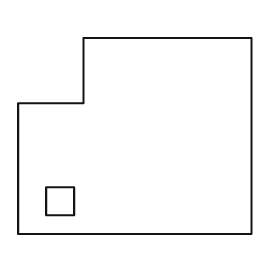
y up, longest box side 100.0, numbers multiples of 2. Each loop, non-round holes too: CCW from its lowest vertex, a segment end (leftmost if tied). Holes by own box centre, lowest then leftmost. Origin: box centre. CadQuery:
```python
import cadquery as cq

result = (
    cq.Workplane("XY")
    .moveTo(-50.0, -42.0)
    .lineTo(50.0, -42.0)
    .lineTo(50.0, 42.0)
    .lineTo(-22.0, 42.0)
    .lineTo(-22.0, 14.0)
    .lineTo(-50.0, 14.0)
    .close()
    .moveTo(-38.0, -34.0)
    .lineTo(-26.0, -34.0)
    .lineTo(-26.0, -22.0)
    .lineTo(-38.0, -22.0)
    .close()
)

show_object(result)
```